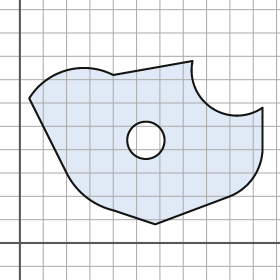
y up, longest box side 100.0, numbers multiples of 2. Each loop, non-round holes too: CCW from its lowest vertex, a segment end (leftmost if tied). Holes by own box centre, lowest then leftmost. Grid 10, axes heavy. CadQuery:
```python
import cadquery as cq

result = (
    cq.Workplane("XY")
    .moveTo(58.0, 8.0)
    .lineTo(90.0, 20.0)
    .threePointArc((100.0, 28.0), (104.0, 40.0))
    .lineTo(104.0, 58.0)
    .threePointArc((82.0, 58.0), (74.0, 78.0))
    .lineTo(40.0, 72.0)
    .threePointArc((20.0, 74.0), (4.0, 62.0))
    .lineTo(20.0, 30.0)
    .threePointArc((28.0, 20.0), (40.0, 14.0))
    .close()
    .moveTo(54.0, 44.0)
    .circle(8.0)
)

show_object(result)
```